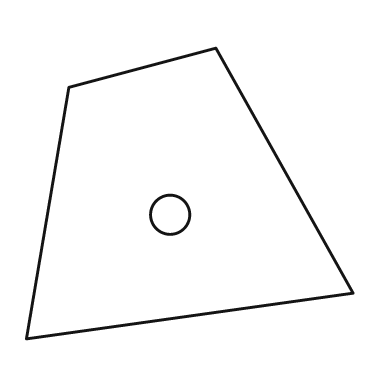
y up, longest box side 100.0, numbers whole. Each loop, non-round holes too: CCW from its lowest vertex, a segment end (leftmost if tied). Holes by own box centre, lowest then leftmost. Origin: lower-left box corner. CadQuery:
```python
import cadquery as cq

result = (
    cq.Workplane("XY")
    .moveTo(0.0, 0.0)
    .lineTo(100.0, 14.0)
    .lineTo(58.0, 89.0)
    .lineTo(13.0, 77.0)
    .close()
    .moveTo(44.0, 38.0)
    .circle(6.0)
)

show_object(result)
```